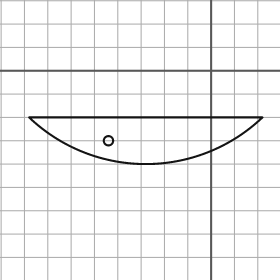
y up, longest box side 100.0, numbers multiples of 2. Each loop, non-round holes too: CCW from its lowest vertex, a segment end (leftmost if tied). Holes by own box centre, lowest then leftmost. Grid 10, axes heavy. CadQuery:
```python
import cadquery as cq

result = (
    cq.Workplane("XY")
    .moveTo(-78.0, -20.0)
    .threePointArc((-28.0, -40.0), (22.0, -20.0))
    .close()
    .moveTo(-44.0, -30.0)
    .circle(2.0)
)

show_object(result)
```